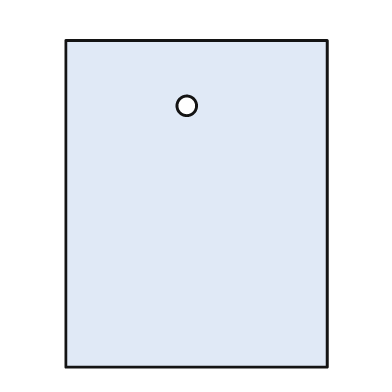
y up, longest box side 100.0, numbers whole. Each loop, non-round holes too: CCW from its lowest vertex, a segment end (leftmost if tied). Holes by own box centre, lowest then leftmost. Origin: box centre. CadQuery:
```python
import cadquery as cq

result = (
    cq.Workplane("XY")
    .moveTo(-40.0, -50.0)
    .lineTo(40.0, -50.0)
    .lineTo(40.0, 50.0)
    .lineTo(-40.0, 50.0)
    .close()
    .moveTo(-3.0, 30.0)
    .circle(3.0)
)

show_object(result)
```